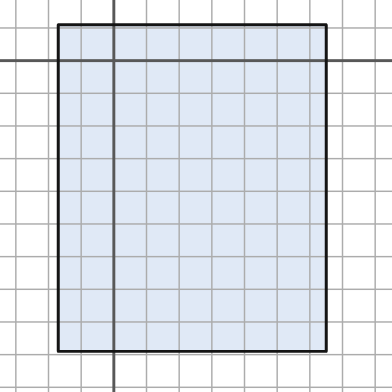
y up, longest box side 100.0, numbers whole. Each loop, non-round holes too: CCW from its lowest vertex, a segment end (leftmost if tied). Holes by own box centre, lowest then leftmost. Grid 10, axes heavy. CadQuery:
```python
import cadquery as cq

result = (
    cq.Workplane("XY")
    .moveTo(-17.0, -89.0)
    .lineTo(65.0, -89.0)
    .lineTo(65.0, 11.0)
    .lineTo(-17.0, 11.0)
    .close()
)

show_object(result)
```